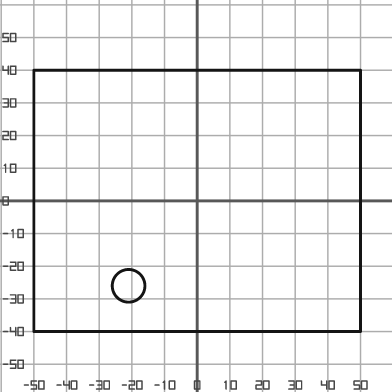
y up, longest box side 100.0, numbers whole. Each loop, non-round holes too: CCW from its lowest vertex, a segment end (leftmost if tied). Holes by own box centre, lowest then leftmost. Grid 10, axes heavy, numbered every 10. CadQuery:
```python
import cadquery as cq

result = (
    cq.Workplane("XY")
    .moveTo(-50.0, -40.0)
    .lineTo(50.0, -40.0)
    .lineTo(50.0, 40.0)
    .lineTo(-50.0, 40.0)
    .close()
    .moveTo(-21.0, -26.0)
    .circle(5.0)
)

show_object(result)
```